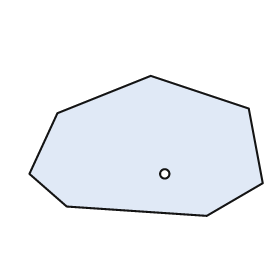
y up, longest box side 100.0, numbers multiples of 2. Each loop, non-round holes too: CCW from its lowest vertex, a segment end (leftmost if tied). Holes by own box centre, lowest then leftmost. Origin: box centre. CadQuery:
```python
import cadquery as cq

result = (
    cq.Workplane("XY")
    .moveTo(26.0, -30.0)
    .lineTo(50.0, -16.0)
    .lineTo(44.0, 16.0)
    .lineTo(2.0, 30.0)
    .lineTo(-38.0, 14.0)
    .lineTo(-50.0, -12.0)
    .lineTo(-34.0, -26.0)
    .close()
    .moveTo(8.0, -12.0)
    .circle(2.0)
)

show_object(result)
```